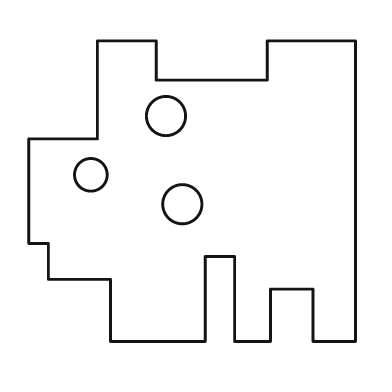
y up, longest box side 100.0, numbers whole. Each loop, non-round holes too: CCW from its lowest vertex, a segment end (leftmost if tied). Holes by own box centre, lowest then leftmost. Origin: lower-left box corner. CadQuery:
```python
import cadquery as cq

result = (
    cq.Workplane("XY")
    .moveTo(25.0, 0.0)
    .lineTo(54.0, 0.0)
    .lineTo(54.0, 26.0)
    .lineTo(63.0, 26.0)
    .lineTo(63.0, 0.0)
    .lineTo(74.0, 0.0)
    .lineTo(74.0, 16.0)
    .lineTo(87.0, 16.0)
    .lineTo(87.0, 0.0)
    .lineTo(100.0, 0.0)
    .lineTo(100.0, 92.0)
    .lineTo(73.0, 92.0)
    .lineTo(73.0, 80.0)
    .lineTo(39.0, 80.0)
    .lineTo(39.0, 92.0)
    .lineTo(21.0, 92.0)
    .lineTo(21.0, 62.0)
    .lineTo(0.0, 62.0)
    .lineTo(0.0, 30.0)
    .lineTo(6.0, 30.0)
    .lineTo(6.0, 19.0)
    .lineTo(25.0, 19.0)
    .close()
    .moveTo(47.0, 42.0)
    .circle(6.0)
    .moveTo(19.0, 51.0)
    .circle(5.0)
    .moveTo(42.0, 69.0)
    .circle(6.0)
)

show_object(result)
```